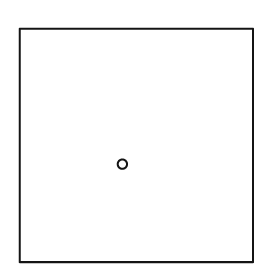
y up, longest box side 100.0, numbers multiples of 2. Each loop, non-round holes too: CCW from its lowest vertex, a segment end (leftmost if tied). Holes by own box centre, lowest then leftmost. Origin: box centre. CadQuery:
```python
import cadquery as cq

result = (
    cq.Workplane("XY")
    .moveTo(-50.0, -50.0)
    .lineTo(50.0, -50.0)
    .lineTo(50.0, 50.0)
    .lineTo(-50.0, 50.0)
    .close()
    .moveTo(-6.0, -8.0)
    .circle(2.0)
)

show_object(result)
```